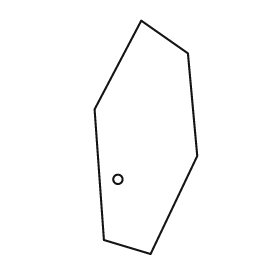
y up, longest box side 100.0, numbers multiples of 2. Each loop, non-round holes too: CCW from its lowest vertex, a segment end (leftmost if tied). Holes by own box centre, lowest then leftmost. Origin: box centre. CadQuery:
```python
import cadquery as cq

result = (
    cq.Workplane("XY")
    .moveTo(2.0, -50.0)
    .lineTo(22.0, -8.0)
    .lineTo(18.0, 36.0)
    .lineTo(-2.0, 50.0)
    .lineTo(-22.0, 12.0)
    .lineTo(-18.0, -44.0)
    .close()
    .moveTo(-12.0, -18.0)
    .circle(2.0)
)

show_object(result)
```